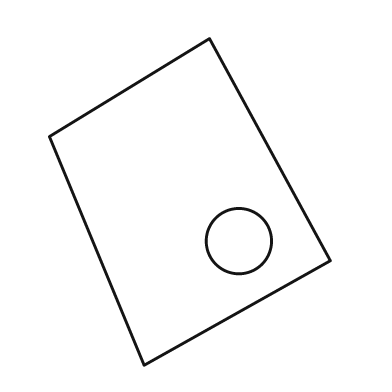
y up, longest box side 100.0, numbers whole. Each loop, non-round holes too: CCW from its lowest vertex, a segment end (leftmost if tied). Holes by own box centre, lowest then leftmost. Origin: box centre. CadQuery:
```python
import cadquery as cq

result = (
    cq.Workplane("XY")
    .moveTo(-14.0, -50.0)
    .lineTo(43.0, -18.0)
    .lineTo(6.0, 50.0)
    .lineTo(-43.0, 20.0)
    .close()
    .moveTo(15.0, -12.0)
    .circle(10.0)
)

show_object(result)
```